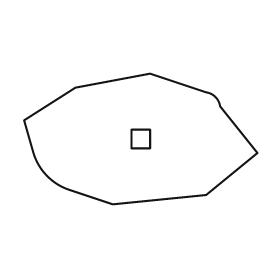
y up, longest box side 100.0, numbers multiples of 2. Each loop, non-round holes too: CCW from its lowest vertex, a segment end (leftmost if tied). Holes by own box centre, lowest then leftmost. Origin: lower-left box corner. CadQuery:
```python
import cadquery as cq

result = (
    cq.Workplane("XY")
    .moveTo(38.0, 0.0)
    .lineTo(78.0, 4.0)
    .lineTo(100.0, 22.0)
    .lineTo(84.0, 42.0)
    .threePointArc((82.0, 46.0), (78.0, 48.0))
    .lineTo(54.0, 56.0)
    .lineTo(22.0, 50.0)
    .lineTo(0.0, 36.0)
    .lineTo(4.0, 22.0)
    .threePointArc((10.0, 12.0), (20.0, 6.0))
    .close()
    .moveTo(46.0, 24.0)
    .lineTo(54.0, 24.0)
    .lineTo(54.0, 32.0)
    .lineTo(46.0, 32.0)
    .close()
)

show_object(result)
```